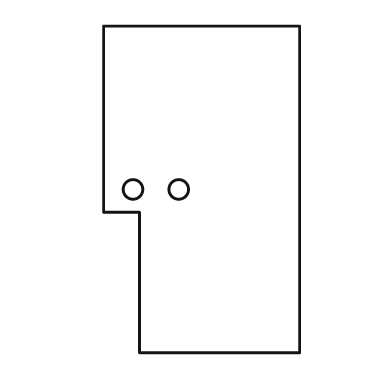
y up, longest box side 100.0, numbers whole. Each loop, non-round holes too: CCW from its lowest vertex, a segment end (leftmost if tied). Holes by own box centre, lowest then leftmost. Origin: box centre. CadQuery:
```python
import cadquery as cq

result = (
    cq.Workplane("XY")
    .moveTo(-19.0, -50.0)
    .lineTo(30.0, -50.0)
    .lineTo(30.0, 50.0)
    .lineTo(-30.0, 50.0)
    .lineTo(-30.0, -7.0)
    .lineTo(-19.0, -7.0)
    .close()
    .moveTo(-21.0, 0.0)
    .circle(3.0)
    .moveTo(-7.0, 0.0)
    .circle(3.0)
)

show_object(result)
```